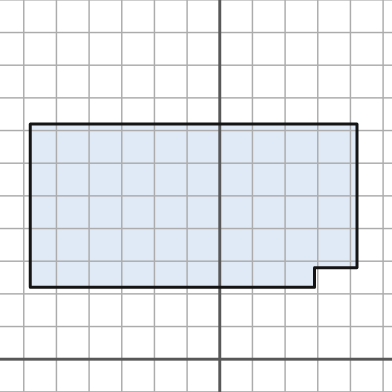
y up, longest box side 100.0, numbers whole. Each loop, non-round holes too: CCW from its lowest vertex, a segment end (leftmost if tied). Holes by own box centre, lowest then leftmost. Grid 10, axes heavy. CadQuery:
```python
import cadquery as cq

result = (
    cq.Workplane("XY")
    .moveTo(-58.0, 22.0)
    .lineTo(29.0, 22.0)
    .lineTo(29.0, 28.0)
    .lineTo(42.0, 28.0)
    .lineTo(42.0, 72.0)
    .lineTo(-58.0, 72.0)
    .close()
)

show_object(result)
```